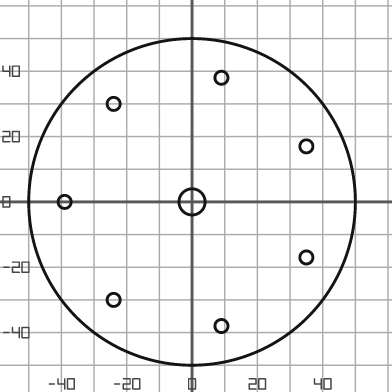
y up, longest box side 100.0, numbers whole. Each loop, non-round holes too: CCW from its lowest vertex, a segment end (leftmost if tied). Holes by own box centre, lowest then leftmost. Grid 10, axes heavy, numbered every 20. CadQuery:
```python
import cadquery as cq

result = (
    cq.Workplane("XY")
    .moveTo(0.0, 0.0)
    .circle(50.0)
    .moveTo(9.0, -38.0)
    .circle(2.0)
    .moveTo(-24.0, -30.0)
    .circle(2.0)
    .moveTo(35.0, -17.0)
    .circle(2.0)
    .moveTo(-39.0, 0.0)
    .circle(2.0)
    .moveTo(0.0, 0.0)
    .circle(4.0)
    .moveTo(35.0, 17.0)
    .circle(2.0)
    .moveTo(-24.0, 30.0)
    .circle(2.0)
    .moveTo(9.0, 38.0)
    .circle(2.0)
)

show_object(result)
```